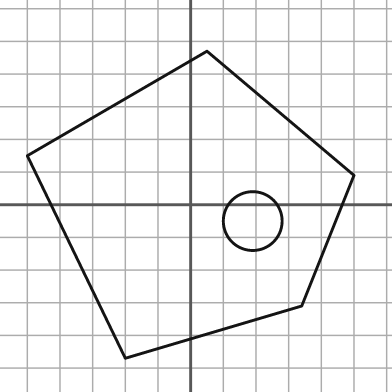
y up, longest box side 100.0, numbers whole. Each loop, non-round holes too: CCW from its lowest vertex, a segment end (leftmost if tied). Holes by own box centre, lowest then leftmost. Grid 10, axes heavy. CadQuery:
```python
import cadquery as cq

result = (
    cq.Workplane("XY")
    .moveTo(-20.0, -47.0)
    .lineTo(34.0, -31.0)
    .lineTo(50.0, 9.0)
    .lineTo(5.0, 47.0)
    .lineTo(-50.0, 15.0)
    .close()
    .moveTo(19.0, -5.0)
    .circle(9.0)
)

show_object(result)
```